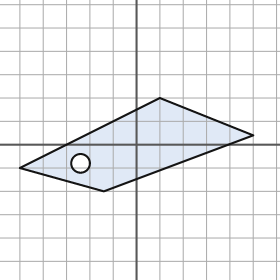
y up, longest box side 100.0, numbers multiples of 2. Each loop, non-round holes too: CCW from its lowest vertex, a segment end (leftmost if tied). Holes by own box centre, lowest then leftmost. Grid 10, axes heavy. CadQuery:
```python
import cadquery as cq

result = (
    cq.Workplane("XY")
    .moveTo(-14.0, -20.0)
    .lineTo(50.0, 4.0)
    .lineTo(10.0, 20.0)
    .lineTo(-50.0, -10.0)
    .close()
    .moveTo(-24.0, -8.0)
    .circle(4.0)
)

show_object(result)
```